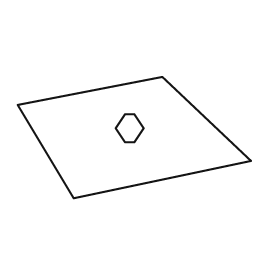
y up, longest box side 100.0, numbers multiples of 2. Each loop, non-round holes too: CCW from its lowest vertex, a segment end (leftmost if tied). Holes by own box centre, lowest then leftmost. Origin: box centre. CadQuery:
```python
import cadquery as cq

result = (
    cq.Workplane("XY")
    .moveTo(-26.0, -26.0)
    .lineTo(50.0, -10.0)
    .lineTo(12.0, 26.0)
    .lineTo(-50.0, 14.0)
    .close()
    .moveTo(-4.0, -2.0)
    .lineTo(0.0, -2.0)
    .lineTo(4.0, 4.0)
    .lineTo(0.0, 10.0)
    .lineTo(-4.0, 10.0)
    .lineTo(-8.0, 4.0)
    .close()
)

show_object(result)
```